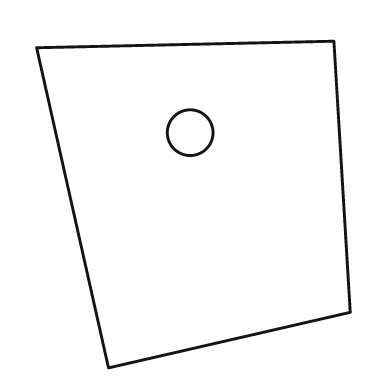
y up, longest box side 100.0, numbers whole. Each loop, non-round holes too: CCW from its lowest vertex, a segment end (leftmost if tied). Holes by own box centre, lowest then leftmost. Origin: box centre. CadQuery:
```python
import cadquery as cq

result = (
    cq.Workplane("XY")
    .moveTo(-26.0, -50.0)
    .lineTo(48.0, -33.0)
    .lineTo(43.0, 50.0)
    .lineTo(-48.0, 48.0)
    .close()
    .moveTo(-1.0, 22.0)
    .circle(7.0)
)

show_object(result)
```